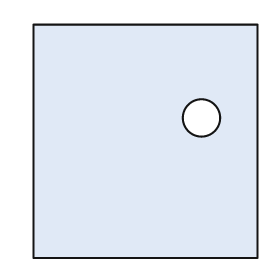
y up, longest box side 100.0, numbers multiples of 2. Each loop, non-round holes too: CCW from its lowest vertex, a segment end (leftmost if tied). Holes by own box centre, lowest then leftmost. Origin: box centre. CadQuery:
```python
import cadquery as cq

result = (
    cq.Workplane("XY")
    .moveTo(-48.0, -50.0)
    .lineTo(48.0, -50.0)
    .lineTo(48.0, 50.0)
    .lineTo(-48.0, 50.0)
    .close()
    .moveTo(24.0, 10.0)
    .circle(8.0)
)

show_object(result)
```